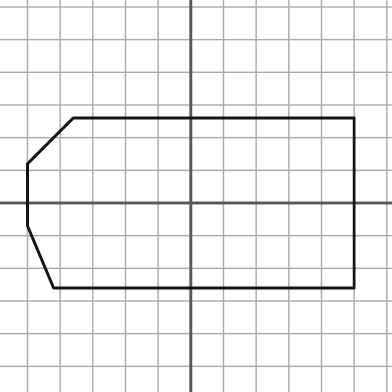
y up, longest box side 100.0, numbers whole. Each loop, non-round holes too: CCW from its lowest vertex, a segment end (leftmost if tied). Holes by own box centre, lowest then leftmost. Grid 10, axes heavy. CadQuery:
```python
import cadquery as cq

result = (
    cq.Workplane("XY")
    .moveTo(-42.0, -26.0)
    .lineTo(50.0, -26.0)
    .lineTo(50.0, 26.0)
    .lineTo(-36.0, 26.0)
    .lineTo(-50.0, 12.0)
    .lineTo(-50.0, -7.0)
    .close()
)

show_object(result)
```